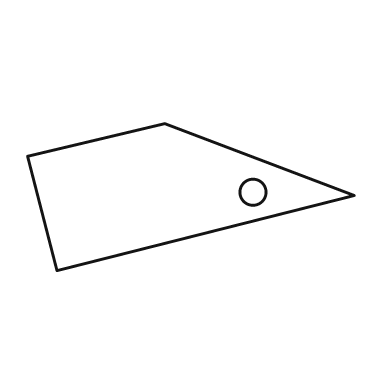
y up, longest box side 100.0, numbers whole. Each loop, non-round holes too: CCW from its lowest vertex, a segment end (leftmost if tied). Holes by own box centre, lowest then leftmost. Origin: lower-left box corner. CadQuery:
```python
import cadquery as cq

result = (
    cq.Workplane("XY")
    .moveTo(9.0, 0.0)
    .lineTo(100.0, 23.0)
    .lineTo(42.0, 45.0)
    .lineTo(0.0, 35.0)
    .close()
    .moveTo(69.0, 24.0)
    .circle(4.0)
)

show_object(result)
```